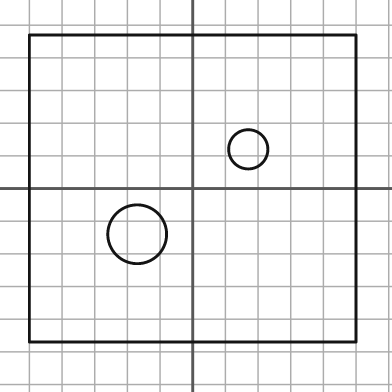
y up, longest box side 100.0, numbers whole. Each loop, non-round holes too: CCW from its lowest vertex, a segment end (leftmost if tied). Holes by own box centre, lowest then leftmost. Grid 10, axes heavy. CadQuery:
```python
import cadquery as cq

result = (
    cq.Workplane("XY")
    .moveTo(-50.0, -47.0)
    .lineTo(50.0, -47.0)
    .lineTo(50.0, 47.0)
    .lineTo(-50.0, 47.0)
    .close()
    .moveTo(-17.0, -14.0)
    .circle(9.0)
    .moveTo(17.0, 12.0)
    .circle(6.0)
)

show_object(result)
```